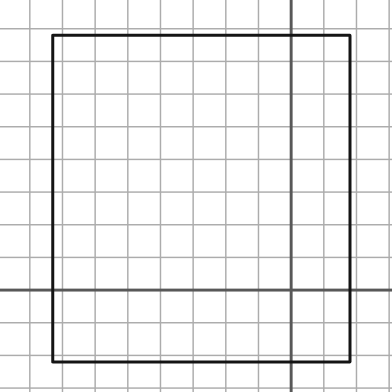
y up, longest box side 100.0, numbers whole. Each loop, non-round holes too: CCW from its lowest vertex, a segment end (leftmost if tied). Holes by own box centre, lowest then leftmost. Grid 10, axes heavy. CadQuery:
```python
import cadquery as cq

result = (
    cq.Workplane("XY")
    .moveTo(-73.0, -22.0)
    .lineTo(18.0, -22.0)
    .lineTo(18.0, 78.0)
    .lineTo(-73.0, 78.0)
    .close()
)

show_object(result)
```